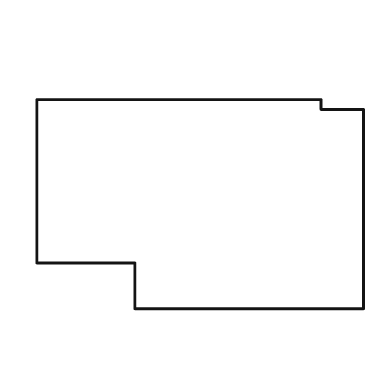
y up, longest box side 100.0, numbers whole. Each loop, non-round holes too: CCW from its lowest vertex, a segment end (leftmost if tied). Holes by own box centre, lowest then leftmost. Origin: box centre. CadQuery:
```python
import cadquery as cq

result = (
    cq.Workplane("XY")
    .moveTo(-20.0, -32.0)
    .lineTo(50.0, -32.0)
    .lineTo(50.0, 29.0)
    .lineTo(37.0, 29.0)
    .lineTo(37.0, 32.0)
    .lineTo(-50.0, 32.0)
    .lineTo(-50.0, -18.0)
    .lineTo(-20.0, -18.0)
    .close()
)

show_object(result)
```